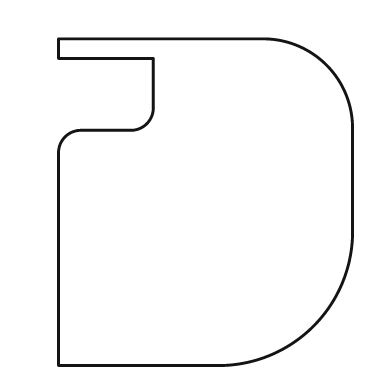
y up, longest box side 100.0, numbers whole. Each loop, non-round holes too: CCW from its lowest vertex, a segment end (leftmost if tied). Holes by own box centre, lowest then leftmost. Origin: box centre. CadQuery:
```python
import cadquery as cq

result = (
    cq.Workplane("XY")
    .moveTo(-45.0, -50.0)
    .lineTo(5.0, -50.0)
    .threePointArc((33.0, -38.0), (45.0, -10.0))
    .lineTo(45.0, 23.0)
    .threePointArc((37.0, 42.0), (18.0, 50.0))
    .lineTo(-45.0, 50.0)
    .lineTo(-45.0, 44.0)
    .lineTo(-16.0, 44.0)
    .lineTo(-16.0, 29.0)
    .threePointArc((-18.0, 24.0), (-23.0, 22.0))
    .lineTo(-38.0, 22.0)
    .threePointArc((-43.0, 20.0), (-45.0, 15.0))
    .close()
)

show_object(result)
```